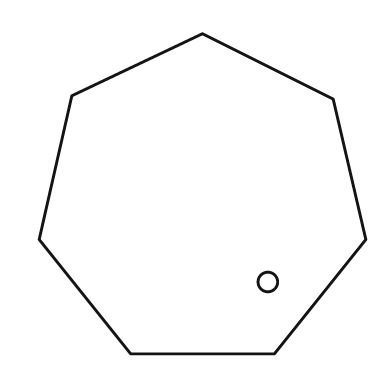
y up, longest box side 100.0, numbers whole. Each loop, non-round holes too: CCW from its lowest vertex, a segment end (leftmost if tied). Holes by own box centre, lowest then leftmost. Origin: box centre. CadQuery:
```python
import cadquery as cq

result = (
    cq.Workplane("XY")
    .moveTo(-22.0, -49.0)
    .lineTo(22.0, -49.0)
    .lineTo(50.0, -14.0)
    .lineTo(40.0, 29.0)
    .lineTo(0.0, 49.0)
    .lineTo(-40.0, 30.0)
    .lineTo(-50.0, -14.0)
    .close()
    .moveTo(20.0, -27.0)
    .circle(3.0)
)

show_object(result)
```